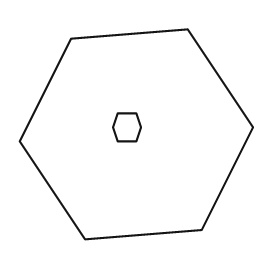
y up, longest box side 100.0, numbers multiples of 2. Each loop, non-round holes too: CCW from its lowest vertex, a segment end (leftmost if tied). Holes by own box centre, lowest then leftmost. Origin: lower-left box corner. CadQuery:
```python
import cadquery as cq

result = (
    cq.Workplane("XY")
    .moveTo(28.0, 0.0)
    .lineTo(78.0, 4.0)
    .lineTo(100.0, 48.0)
    .lineTo(72.0, 90.0)
    .lineTo(22.0, 86.0)
    .lineTo(0.0, 42.0)
    .close()
    .moveTo(42.0, 42.0)
    .lineTo(50.0, 42.0)
    .lineTo(52.0, 48.0)
    .lineTo(50.0, 54.0)
    .lineTo(42.0, 54.0)
    .lineTo(40.0, 48.0)
    .close()
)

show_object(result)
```